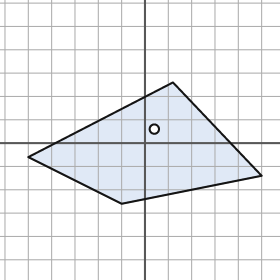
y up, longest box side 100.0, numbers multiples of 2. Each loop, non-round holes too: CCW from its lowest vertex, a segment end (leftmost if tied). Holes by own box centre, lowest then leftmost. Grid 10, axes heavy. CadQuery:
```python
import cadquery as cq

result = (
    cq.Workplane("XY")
    .moveTo(-10.0, -26.0)
    .lineTo(50.0, -14.0)
    .lineTo(12.0, 26.0)
    .lineTo(-50.0, -6.0)
    .close()
    .moveTo(4.0, 6.0)
    .circle(2.0)
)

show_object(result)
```